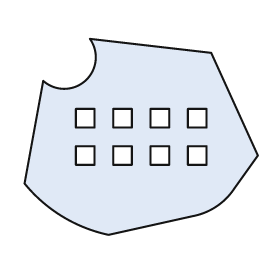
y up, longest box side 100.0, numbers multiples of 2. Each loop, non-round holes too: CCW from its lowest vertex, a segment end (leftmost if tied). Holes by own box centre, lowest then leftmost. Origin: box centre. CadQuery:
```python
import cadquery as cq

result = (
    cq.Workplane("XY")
    .moveTo(-14.0, -42.0)
    .lineTo(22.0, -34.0)
    .threePointArc((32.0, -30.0), (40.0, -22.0))
    .lineTo(50.0, -8.0)
    .lineTo(30.0, 36.0)
    .lineTo(-22.0, 42.0)
    .threePointArc((-24.0, 24.0), (-42.0, 24.0))
    .lineTo(-50.0, -20.0)
    .threePointArc((-34.0, -34.0), (-14.0, -42.0))
    .close()
    .moveTo(-28.0, -12.0)
    .lineTo(-20.0, -12.0)
    .lineTo(-20.0, -4.0)
    .lineTo(-28.0, -4.0)
    .close()
    .moveTo(-12.0, -12.0)
    .lineTo(-4.0, -12.0)
    .lineTo(-4.0, -4.0)
    .lineTo(-12.0, -4.0)
    .close()
    .moveTo(4.0, -12.0)
    .lineTo(12.0, -12.0)
    .lineTo(12.0, -4.0)
    .lineTo(4.0, -4.0)
    .close()
    .moveTo(20.0, -12.0)
    .lineTo(28.0, -12.0)
    .lineTo(28.0, -4.0)
    .lineTo(20.0, -4.0)
    .close()
    .moveTo(-28.0, 4.0)
    .lineTo(-20.0, 4.0)
    .lineTo(-20.0, 12.0)
    .lineTo(-28.0, 12.0)
    .close()
    .moveTo(-12.0, 4.0)
    .lineTo(-4.0, 4.0)
    .lineTo(-4.0, 12.0)
    .lineTo(-12.0, 12.0)
    .close()
    .moveTo(4.0, 4.0)
    .lineTo(12.0, 4.0)
    .lineTo(12.0, 12.0)
    .lineTo(4.0, 12.0)
    .close()
    .moveTo(20.0, 4.0)
    .lineTo(28.0, 4.0)
    .lineTo(28.0, 12.0)
    .lineTo(20.0, 12.0)
    .close()
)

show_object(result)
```